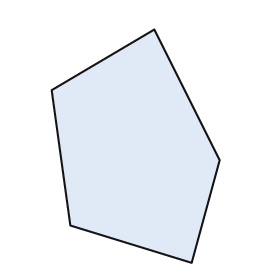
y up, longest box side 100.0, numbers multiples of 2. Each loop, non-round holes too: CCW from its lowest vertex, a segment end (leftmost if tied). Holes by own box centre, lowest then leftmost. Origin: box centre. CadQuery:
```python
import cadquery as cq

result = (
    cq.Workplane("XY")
    .moveTo(24.0, -50.0)
    .lineTo(36.0, -6.0)
    .lineTo(8.0, 50.0)
    .lineTo(-36.0, 24.0)
    .lineTo(-28.0, -34.0)
    .close()
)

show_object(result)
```